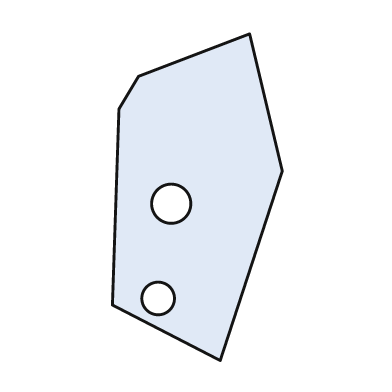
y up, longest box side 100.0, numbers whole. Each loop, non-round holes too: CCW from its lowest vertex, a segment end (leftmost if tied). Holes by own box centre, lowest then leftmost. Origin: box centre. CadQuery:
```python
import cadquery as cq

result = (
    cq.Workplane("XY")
    .moveTo(7.0, -50.0)
    .lineTo(26.0, 8.0)
    .lineTo(16.0, 50.0)
    .lineTo(-18.0, 37.0)
    .lineTo(-24.0, 27.0)
    .lineTo(-26.0, -33.0)
    .close()
    .moveTo(-12.0, -31.0)
    .circle(5.0)
    .moveTo(-8.0, -2.0)
    .circle(6.0)
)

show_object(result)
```